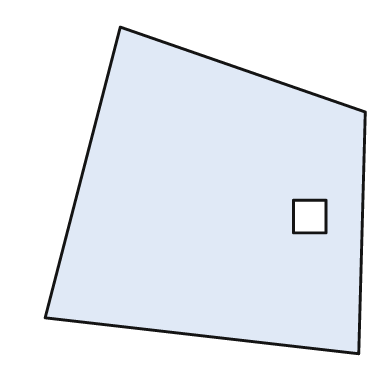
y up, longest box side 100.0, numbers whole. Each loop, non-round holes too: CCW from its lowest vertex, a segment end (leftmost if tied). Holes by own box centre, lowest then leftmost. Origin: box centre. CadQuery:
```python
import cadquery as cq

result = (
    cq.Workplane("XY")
    .moveTo(47.0, -50.0)
    .lineTo(49.0, 24.0)
    .lineTo(-26.0, 50.0)
    .lineTo(-49.0, -39.0)
    .close()
    .moveTo(27.0, -13.0)
    .lineTo(37.0, -13.0)
    .lineTo(37.0, -3.0)
    .lineTo(27.0, -3.0)
    .close()
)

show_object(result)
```